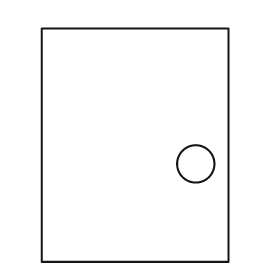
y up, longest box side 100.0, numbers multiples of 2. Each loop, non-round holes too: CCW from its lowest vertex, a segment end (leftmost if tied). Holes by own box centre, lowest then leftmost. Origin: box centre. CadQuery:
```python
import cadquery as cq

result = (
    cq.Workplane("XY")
    .moveTo(-40.0, -50.0)
    .lineTo(40.0, -50.0)
    .lineTo(40.0, 50.0)
    .lineTo(-40.0, 50.0)
    .close()
    .moveTo(26.0, -8.0)
    .circle(8.0)
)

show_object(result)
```